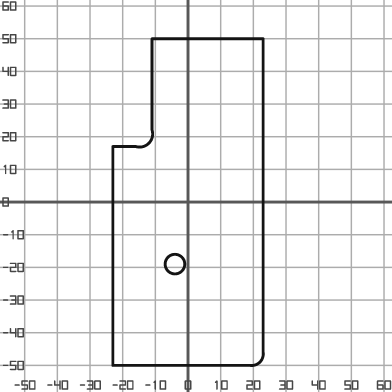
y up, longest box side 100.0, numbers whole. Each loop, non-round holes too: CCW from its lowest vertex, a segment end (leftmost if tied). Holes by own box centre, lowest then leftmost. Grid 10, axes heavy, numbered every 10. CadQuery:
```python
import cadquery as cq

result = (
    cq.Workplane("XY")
    .moveTo(-23.0, -50.0)
    .lineTo(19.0, -50.0)
    .threePointArc((22.0, -49.0), (23.0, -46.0))
    .lineTo(23.0, 50.0)
    .lineTo(-11.0, 50.0)
    .lineTo(-11.0, 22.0)
    .threePointArc((-12.0, 18.0), (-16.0, 17.0))
    .lineTo(-23.0, 17.0)
    .close()
    .moveTo(-4.0, -19.0)
    .circle(3.0)
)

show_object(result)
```